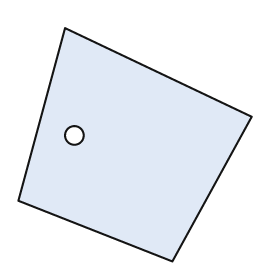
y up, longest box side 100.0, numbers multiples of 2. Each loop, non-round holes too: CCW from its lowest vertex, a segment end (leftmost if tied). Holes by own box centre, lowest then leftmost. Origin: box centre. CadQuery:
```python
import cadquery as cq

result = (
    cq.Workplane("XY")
    .moveTo(16.0, -50.0)
    .lineTo(50.0, 12.0)
    .lineTo(-30.0, 50.0)
    .lineTo(-50.0, -24.0)
    .close()
    .moveTo(-26.0, 4.0)
    .circle(4.0)
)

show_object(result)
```